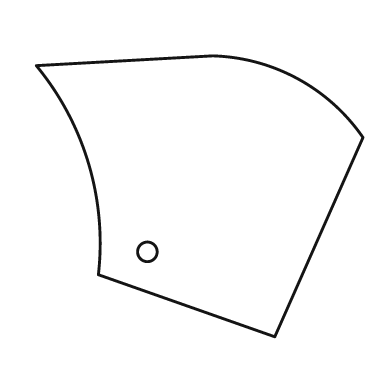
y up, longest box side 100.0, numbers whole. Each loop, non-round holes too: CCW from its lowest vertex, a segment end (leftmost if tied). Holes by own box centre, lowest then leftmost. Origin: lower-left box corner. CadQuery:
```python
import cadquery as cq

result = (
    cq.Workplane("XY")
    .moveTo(73.0, 0.0)
    .lineTo(100.0, 61.0)
    .threePointArc((80.0, 79.0), (54.0, 86.0))
    .lineTo(0.0, 83.0)
    .threePointArc((16.0, 53.0), (19.0, 19.0))
    .close()
    .moveTo(34.0, 26.0)
    .circle(3.0)
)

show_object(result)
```